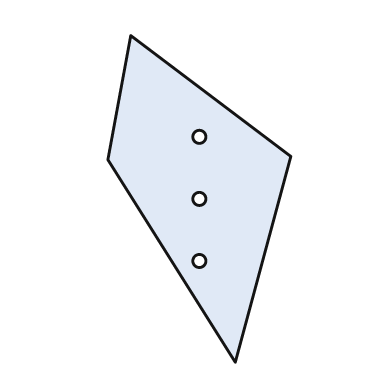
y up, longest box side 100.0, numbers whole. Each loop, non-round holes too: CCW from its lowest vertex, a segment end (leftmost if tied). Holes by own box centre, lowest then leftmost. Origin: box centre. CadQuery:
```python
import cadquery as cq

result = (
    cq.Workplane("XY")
    .moveTo(11.0, -50.0)
    .lineTo(28.0, 13.0)
    .lineTo(-21.0, 50.0)
    .lineTo(-28.0, 12.0)
    .close()
    .moveTo(0.0, -19.0)
    .circle(2.0)
    .moveTo(0.0, 0.0)
    .circle(2.0)
    .moveTo(0.0, 19.0)
    .circle(2.0)
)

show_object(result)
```